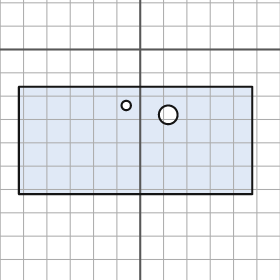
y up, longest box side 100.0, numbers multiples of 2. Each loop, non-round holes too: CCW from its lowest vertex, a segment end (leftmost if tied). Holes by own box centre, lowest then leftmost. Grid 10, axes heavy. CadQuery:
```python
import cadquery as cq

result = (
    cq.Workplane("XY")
    .moveTo(-52.0, -62.0)
    .lineTo(48.0, -62.0)
    .lineTo(48.0, -16.0)
    .lineTo(-52.0, -16.0)
    .close()
    .moveTo(12.0, -28.0)
    .circle(4.0)
    .moveTo(-6.0, -24.0)
    .circle(2.0)
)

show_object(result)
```